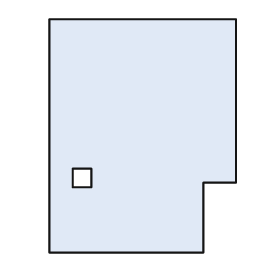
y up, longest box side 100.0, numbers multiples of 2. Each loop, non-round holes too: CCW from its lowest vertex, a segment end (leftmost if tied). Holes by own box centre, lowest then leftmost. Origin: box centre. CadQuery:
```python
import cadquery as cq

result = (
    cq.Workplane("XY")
    .moveTo(-40.0, -50.0)
    .lineTo(26.0, -50.0)
    .lineTo(26.0, -20.0)
    .lineTo(40.0, -20.0)
    .lineTo(40.0, 50.0)
    .lineTo(-40.0, 50.0)
    .close()
    .moveTo(-30.0, -22.0)
    .lineTo(-22.0, -22.0)
    .lineTo(-22.0, -14.0)
    .lineTo(-30.0, -14.0)
    .close()
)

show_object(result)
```